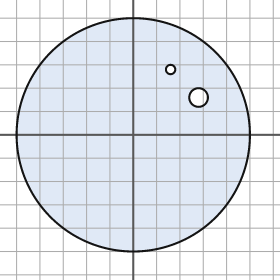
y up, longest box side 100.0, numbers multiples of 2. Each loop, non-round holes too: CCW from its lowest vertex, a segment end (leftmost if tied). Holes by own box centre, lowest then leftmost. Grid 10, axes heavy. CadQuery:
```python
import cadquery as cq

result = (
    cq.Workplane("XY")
    .moveTo(0.0, 0.0)
    .circle(50.0)
    .moveTo(28.0, 16.0)
    .circle(4.0)
    .moveTo(16.0, 28.0)
    .circle(2.0)
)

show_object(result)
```